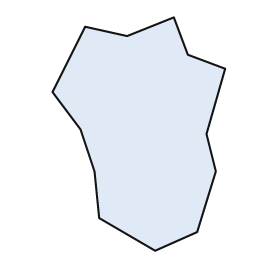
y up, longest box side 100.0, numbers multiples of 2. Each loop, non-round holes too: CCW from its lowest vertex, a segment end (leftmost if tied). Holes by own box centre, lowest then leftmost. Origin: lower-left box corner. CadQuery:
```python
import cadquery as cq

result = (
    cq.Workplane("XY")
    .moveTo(44.0, 0.0)
    .lineTo(62.0, 8.0)
    .lineTo(70.0, 34.0)
    .lineTo(66.0, 50.0)
    .lineTo(74.0, 78.0)
    .lineTo(58.0, 84.0)
    .lineTo(52.0, 100.0)
    .lineTo(32.0, 92.0)
    .lineTo(14.0, 96.0)
    .lineTo(0.0, 68.0)
    .lineTo(12.0, 52.0)
    .lineTo(18.0, 34.0)
    .lineTo(20.0, 14.0)
    .close()
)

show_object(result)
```